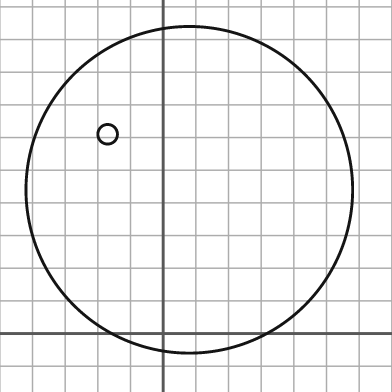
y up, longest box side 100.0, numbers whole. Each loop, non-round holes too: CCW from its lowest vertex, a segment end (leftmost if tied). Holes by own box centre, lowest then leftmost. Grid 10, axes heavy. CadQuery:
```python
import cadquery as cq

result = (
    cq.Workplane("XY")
    .moveTo(8.0, 44.0)
    .circle(50.0)
    .moveTo(-17.0, 61.0)
    .circle(3.0)
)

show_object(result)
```